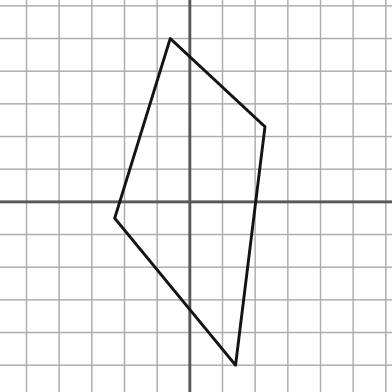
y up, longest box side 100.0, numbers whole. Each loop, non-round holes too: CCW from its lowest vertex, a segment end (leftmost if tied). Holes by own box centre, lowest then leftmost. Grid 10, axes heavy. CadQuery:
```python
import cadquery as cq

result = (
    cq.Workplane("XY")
    .moveTo(14.0, -50.0)
    .lineTo(23.0, 23.0)
    .lineTo(-6.0, 50.0)
    .lineTo(-23.0, -5.0)
    .close()
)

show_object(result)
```